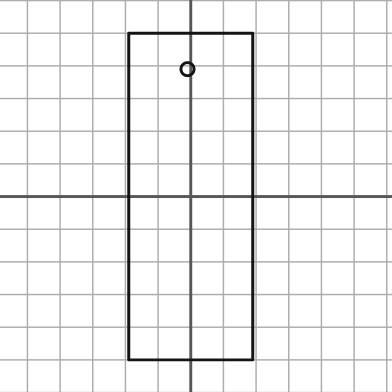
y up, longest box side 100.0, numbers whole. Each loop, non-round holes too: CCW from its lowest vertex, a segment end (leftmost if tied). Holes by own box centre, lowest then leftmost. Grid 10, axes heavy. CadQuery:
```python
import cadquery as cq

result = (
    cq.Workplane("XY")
    .moveTo(-19.0, -50.0)
    .lineTo(19.0, -50.0)
    .lineTo(19.0, 50.0)
    .lineTo(-19.0, 50.0)
    .close()
    .moveTo(-1.0, 39.0)
    .circle(2.0)
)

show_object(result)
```